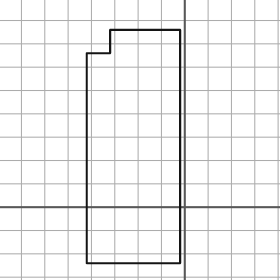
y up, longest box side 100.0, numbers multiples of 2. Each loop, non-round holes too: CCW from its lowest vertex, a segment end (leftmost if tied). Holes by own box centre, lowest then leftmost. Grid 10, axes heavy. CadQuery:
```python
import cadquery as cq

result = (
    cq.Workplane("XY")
    .moveTo(-42.0, -24.0)
    .lineTo(-2.0, -24.0)
    .lineTo(-2.0, 76.0)
    .lineTo(-32.0, 76.0)
    .lineTo(-32.0, 66.0)
    .lineTo(-42.0, 66.0)
    .close()
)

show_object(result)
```